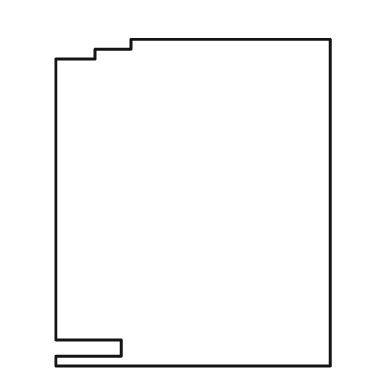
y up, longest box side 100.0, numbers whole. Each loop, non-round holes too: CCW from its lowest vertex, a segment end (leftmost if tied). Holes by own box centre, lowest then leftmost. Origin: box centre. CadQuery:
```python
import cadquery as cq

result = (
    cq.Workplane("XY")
    .moveTo(-42.0, -50.0)
    .lineTo(42.0, -50.0)
    .lineTo(42.0, 50.0)
    .lineTo(-19.0, 50.0)
    .lineTo(-19.0, 47.0)
    .lineTo(-30.0, 47.0)
    .lineTo(-30.0, 44.0)
    .lineTo(-42.0, 44.0)
    .lineTo(-42.0, -42.0)
    .lineTo(-22.0, -42.0)
    .lineTo(-22.0, -47.0)
    .lineTo(-42.0, -47.0)
    .close()
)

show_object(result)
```